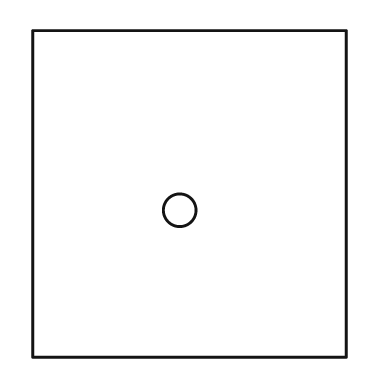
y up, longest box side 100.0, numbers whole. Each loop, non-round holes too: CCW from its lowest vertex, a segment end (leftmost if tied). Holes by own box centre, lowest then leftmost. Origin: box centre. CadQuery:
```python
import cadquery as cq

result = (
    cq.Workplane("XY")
    .moveTo(-48.0, -50.0)
    .lineTo(48.0, -50.0)
    .lineTo(48.0, 50.0)
    .lineTo(-48.0, 50.0)
    .close()
    .moveTo(-3.0, -5.0)
    .circle(5.0)
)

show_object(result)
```